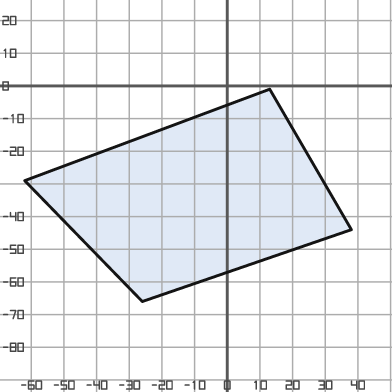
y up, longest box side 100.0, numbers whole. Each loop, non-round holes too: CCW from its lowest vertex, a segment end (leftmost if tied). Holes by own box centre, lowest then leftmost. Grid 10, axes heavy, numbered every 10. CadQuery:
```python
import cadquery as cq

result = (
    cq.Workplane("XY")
    .moveTo(-26.0, -66.0)
    .lineTo(38.0, -44.0)
    .lineTo(13.0, -1.0)
    .lineTo(-62.0, -29.0)
    .close()
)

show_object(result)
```